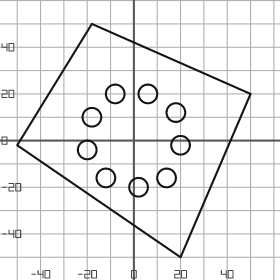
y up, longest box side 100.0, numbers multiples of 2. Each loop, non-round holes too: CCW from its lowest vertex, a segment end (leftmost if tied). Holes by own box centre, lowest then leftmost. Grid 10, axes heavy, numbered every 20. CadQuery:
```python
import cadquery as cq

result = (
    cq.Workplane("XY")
    .moveTo(20.0, -50.0)
    .lineTo(50.0, 20.0)
    .lineTo(-18.0, 50.0)
    .lineTo(-50.0, -2.0)
    .close()
    .moveTo(2.0, -20.0)
    .circle(4.0)
    .moveTo(-12.0, -16.0)
    .circle(4.0)
    .moveTo(14.0, -16.0)
    .circle(4.0)
    .moveTo(-20.0, -4.0)
    .circle(4.0)
    .moveTo(20.0, -2.0)
    .circle(4.0)
    .moveTo(-18.0, 10.0)
    .circle(4.0)
    .moveTo(18.0, 12.0)
    .circle(4.0)
    .moveTo(-8.0, 20.0)
    .circle(4.0)
    .moveTo(6.0, 20.0)
    .circle(4.0)
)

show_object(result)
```